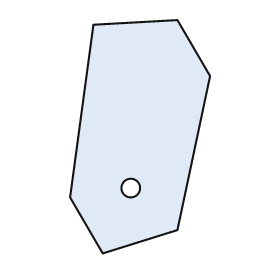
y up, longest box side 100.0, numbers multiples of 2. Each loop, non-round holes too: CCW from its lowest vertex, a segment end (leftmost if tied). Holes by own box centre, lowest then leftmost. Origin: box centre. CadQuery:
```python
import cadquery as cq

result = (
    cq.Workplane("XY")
    .moveTo(-16.0, -50.0)
    .lineTo(16.0, -40.0)
    .lineTo(30.0, 26.0)
    .lineTo(16.0, 50.0)
    .lineTo(-20.0, 48.0)
    .lineTo(-30.0, -26.0)
    .close()
    .moveTo(-4.0, -22.0)
    .circle(4.0)
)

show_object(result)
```